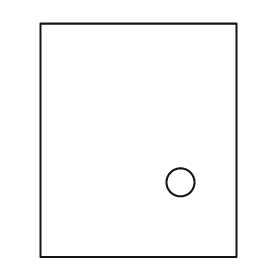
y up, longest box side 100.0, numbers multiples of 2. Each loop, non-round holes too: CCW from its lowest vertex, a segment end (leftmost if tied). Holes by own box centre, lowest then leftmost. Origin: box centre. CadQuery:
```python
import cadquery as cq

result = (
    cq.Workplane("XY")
    .moveTo(-42.0, -50.0)
    .lineTo(42.0, -50.0)
    .lineTo(42.0, 50.0)
    .lineTo(-42.0, 50.0)
    .close()
    .moveTo(18.0, -18.0)
    .circle(6.0)
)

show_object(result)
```